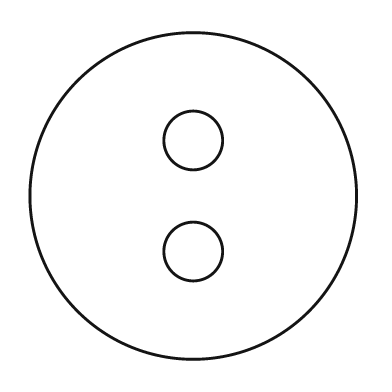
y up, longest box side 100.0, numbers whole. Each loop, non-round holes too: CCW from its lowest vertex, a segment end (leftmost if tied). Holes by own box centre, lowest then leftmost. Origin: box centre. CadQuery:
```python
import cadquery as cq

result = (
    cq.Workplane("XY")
    .moveTo(0.0, 0.0)
    .circle(50.0)
    .moveTo(0.0, -17.0)
    .circle(9.0)
    .moveTo(0.0, 17.0)
    .circle(9.0)
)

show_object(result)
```